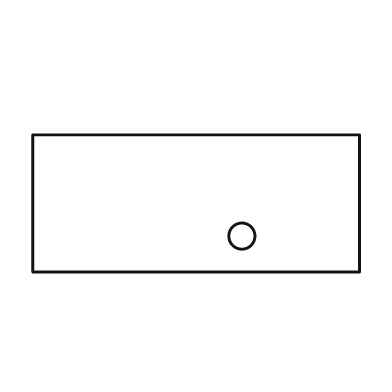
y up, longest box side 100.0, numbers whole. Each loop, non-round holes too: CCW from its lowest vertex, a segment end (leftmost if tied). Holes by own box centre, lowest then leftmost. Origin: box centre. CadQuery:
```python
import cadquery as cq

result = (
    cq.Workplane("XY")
    .moveTo(-50.0, -21.0)
    .lineTo(50.0, -21.0)
    .lineTo(50.0, 21.0)
    .lineTo(-50.0, 21.0)
    .close()
    .moveTo(14.0, -10.0)
    .circle(4.0)
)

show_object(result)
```